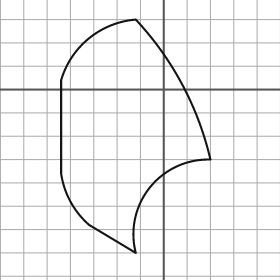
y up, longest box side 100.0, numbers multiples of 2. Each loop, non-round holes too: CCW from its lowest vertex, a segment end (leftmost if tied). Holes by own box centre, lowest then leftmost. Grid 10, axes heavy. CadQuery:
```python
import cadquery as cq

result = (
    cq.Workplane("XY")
    .moveTo(-12.0, -70.0)
    .threePointArc((-6.0, -42.0), (20.0, -30.0))
    .threePointArc((8.0, 2.0), (-12.0, 30.0))
    .threePointArc((-32.0, 22.0), (-44.0, 4.0))
    .lineTo(-44.0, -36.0)
    .threePointArc((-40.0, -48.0), (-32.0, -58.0))
    .close()
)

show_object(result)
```